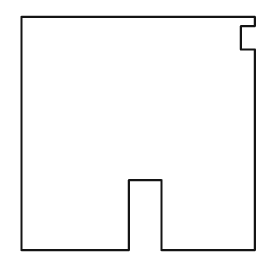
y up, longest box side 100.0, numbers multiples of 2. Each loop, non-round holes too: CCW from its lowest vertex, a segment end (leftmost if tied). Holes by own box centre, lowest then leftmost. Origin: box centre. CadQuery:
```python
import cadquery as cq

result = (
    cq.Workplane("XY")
    .moveTo(-50.0, -50.0)
    .lineTo(-4.0, -50.0)
    .lineTo(-4.0, -20.0)
    .lineTo(10.0, -20.0)
    .lineTo(10.0, -50.0)
    .lineTo(50.0, -50.0)
    .lineTo(50.0, 36.0)
    .lineTo(44.0, 36.0)
    .lineTo(44.0, 46.0)
    .lineTo(50.0, 46.0)
    .lineTo(50.0, 50.0)
    .lineTo(-50.0, 50.0)
    .close()
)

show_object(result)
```